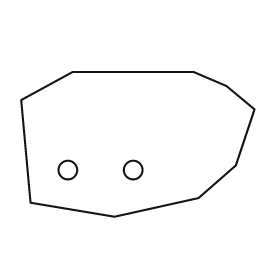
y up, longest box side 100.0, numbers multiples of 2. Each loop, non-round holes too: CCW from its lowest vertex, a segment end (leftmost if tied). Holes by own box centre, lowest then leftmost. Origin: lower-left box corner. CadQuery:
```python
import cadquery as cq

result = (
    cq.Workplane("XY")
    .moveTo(40.0, 0.0)
    .lineTo(76.0, 8.0)
    .lineTo(92.0, 22.0)
    .lineTo(100.0, 46.0)
    .lineTo(88.0, 56.0)
    .lineTo(74.0, 62.0)
    .lineTo(22.0, 62.0)
    .lineTo(0.0, 50.0)
    .lineTo(4.0, 6.0)
    .close()
    .moveTo(20.0, 20.0)
    .circle(4.0)
    .moveTo(48.0, 20.0)
    .circle(4.0)
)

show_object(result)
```